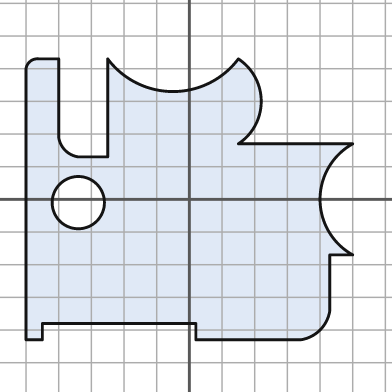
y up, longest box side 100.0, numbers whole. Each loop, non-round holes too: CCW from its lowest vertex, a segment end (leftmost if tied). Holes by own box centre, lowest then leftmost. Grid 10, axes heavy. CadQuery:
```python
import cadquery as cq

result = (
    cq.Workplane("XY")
    .moveTo(-50.0, -43.0)
    .lineTo(-45.0, -43.0)
    .lineTo(-45.0, -38.0)
    .lineTo(2.0, -38.0)
    .lineTo(2.0, -43.0)
    .lineTo(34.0, -43.0)
    .threePointArc((40.0, -40.0), (43.0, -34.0))
    .lineTo(43.0, -17.0)
    .lineTo(50.0, -17.0)
    .threePointArc((40.0, 0.0), (50.0, 17.0))
    .lineTo(15.0, 17.0)
    .threePointArc((22.0, 30.0), (15.0, 43.0))
    .threePointArc((-5.0, 33.0), (-25.0, 43.0))
    .lineTo(-25.0, 13.0)
    .lineTo(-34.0, 13.0)
    .threePointArc((-38.0, 15.0), (-40.0, 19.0))
    .lineTo(-40.0, 43.0)
    .lineTo(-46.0, 43.0)
    .threePointArc((-49.0, 42.0), (-50.0, 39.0))
    .close()
    .moveTo(-34.0, -1.0)
    .circle(8.0)
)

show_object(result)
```